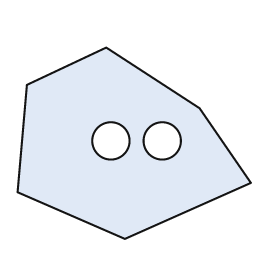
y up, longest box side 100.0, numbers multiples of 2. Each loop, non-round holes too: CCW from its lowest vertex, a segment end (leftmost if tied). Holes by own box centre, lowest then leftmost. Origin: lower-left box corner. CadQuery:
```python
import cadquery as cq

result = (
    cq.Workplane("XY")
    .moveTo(46.0, 0.0)
    .lineTo(100.0, 24.0)
    .lineTo(78.0, 56.0)
    .lineTo(38.0, 82.0)
    .lineTo(4.0, 66.0)
    .lineTo(0.0, 20.0)
    .close()
    .moveTo(40.0, 42.0)
    .circle(8.0)
    .moveTo(62.0, 42.0)
    .circle(8.0)
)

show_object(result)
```